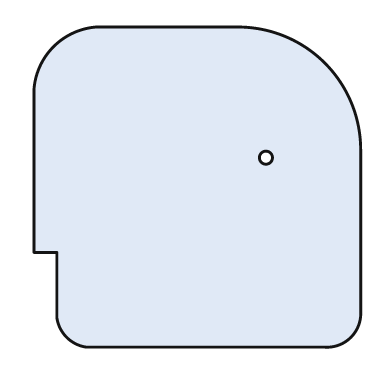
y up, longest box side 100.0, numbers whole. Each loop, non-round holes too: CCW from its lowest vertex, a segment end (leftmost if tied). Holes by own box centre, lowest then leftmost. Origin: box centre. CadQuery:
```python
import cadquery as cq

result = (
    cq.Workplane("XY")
    .moveTo(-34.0, -49.0)
    .lineTo(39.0, -49.0)
    .threePointArc((47.0, -46.0), (50.0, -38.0))
    .lineTo(50.0, 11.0)
    .threePointArc((39.0, 38.0), (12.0, 49.0))
    .lineTo(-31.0, 49.0)
    .threePointArc((-44.0, 43.0), (-50.0, 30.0))
    .lineTo(-50.0, -20.0)
    .lineTo(-43.0, -20.0)
    .lineTo(-43.0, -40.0)
    .threePointArc((-40.0, -46.0), (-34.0, -49.0))
    .close()
    .moveTo(21.0, 9.0)
    .circle(2.0)
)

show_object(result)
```